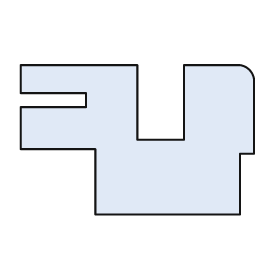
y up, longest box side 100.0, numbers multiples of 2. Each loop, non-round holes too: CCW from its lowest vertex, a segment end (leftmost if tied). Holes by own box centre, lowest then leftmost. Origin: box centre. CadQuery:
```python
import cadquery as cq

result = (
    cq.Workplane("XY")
    .moveTo(-18.0, -32.0)
    .lineTo(44.0, -32.0)
    .lineTo(44.0, -6.0)
    .lineTo(50.0, -6.0)
    .lineTo(50.0, 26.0)
    .threePointArc((48.0, 30.0), (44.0, 32.0))
    .lineTo(20.0, 32.0)
    .lineTo(20.0, 0.0)
    .lineTo(0.0, 0.0)
    .lineTo(0.0, 32.0)
    .lineTo(-50.0, 32.0)
    .lineTo(-50.0, 20.0)
    .lineTo(-22.0, 20.0)
    .lineTo(-22.0, 14.0)
    .lineTo(-50.0, 14.0)
    .lineTo(-50.0, -4.0)
    .lineTo(-18.0, -4.0)
    .close()
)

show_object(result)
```